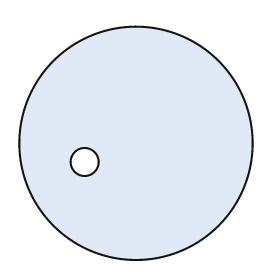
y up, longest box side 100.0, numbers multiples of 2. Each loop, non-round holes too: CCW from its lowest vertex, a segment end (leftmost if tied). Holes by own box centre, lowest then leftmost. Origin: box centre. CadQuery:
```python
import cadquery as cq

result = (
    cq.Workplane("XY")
    .moveTo(0.0, 0.0)
    .circle(50.0)
    .moveTo(-22.0, -8.0)
    .circle(6.0)
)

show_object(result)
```